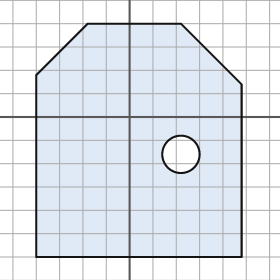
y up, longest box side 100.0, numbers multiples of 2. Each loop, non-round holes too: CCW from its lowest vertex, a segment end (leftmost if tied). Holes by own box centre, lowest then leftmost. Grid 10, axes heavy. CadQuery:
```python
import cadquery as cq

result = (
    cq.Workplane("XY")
    .moveTo(-40.0, -60.0)
    .lineTo(48.0, -60.0)
    .lineTo(48.0, 14.0)
    .lineTo(22.0, 40.0)
    .lineTo(-18.0, 40.0)
    .lineTo(-40.0, 18.0)
    .close()
    .moveTo(22.0, -16.0)
    .circle(8.0)
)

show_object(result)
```